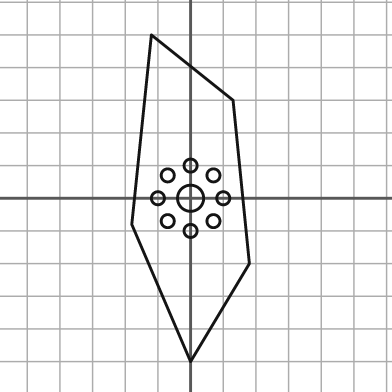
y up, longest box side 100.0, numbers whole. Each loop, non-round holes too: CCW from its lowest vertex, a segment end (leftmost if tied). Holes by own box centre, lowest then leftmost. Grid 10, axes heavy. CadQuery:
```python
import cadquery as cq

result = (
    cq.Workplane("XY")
    .moveTo(0.0, -50.0)
    .lineTo(18.0, -20.0)
    .lineTo(13.0, 30.0)
    .lineTo(-12.0, 50.0)
    .lineTo(-18.0, -8.0)
    .close()
    .moveTo(0.0, -10.0)
    .circle(2.0)
    .moveTo(-7.0, -7.0)
    .circle(2.0)
    .moveTo(7.0, -7.0)
    .circle(2.0)
    .moveTo(-10.0, 0.0)
    .circle(2.0)
    .moveTo(0.0, 0.0)
    .circle(4.0)
    .moveTo(10.0, 0.0)
    .circle(2.0)
    .moveTo(-7.0, 7.0)
    .circle(2.0)
    .moveTo(7.0, 7.0)
    .circle(2.0)
    .moveTo(0.0, 10.0)
    .circle(2.0)
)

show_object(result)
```